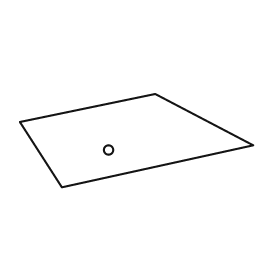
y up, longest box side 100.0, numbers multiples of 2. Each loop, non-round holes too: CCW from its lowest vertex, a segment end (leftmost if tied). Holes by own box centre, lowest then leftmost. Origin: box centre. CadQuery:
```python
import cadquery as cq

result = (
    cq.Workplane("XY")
    .moveTo(-32.0, -20.0)
    .lineTo(50.0, -2.0)
    .lineTo(8.0, 20.0)
    .lineTo(-50.0, 8.0)
    .close()
    .moveTo(-12.0, -4.0)
    .circle(2.0)
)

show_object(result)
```